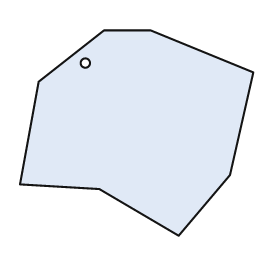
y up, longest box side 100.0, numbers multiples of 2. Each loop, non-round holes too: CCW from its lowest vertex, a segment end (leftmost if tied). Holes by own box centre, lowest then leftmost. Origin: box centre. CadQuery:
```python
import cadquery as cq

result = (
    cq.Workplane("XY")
    .moveTo(18.0, -44.0)
    .lineTo(40.0, -18.0)
    .lineTo(50.0, 26.0)
    .lineTo(6.0, 44.0)
    .lineTo(-14.0, 44.0)
    .lineTo(-42.0, 22.0)
    .lineTo(-50.0, -22.0)
    .lineTo(-16.0, -24.0)
    .close()
    .moveTo(-22.0, 30.0)
    .circle(2.0)
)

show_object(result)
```